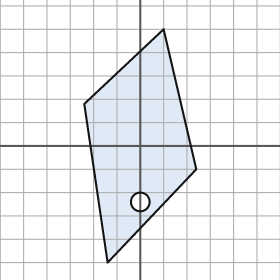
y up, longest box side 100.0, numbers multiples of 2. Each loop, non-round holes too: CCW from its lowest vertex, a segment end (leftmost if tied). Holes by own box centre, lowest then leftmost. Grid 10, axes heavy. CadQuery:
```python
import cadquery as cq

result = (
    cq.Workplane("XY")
    .moveTo(-14.0, -50.0)
    .lineTo(24.0, -10.0)
    .lineTo(10.0, 50.0)
    .lineTo(-24.0, 18.0)
    .close()
    .moveTo(0.0, -24.0)
    .circle(4.0)
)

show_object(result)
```